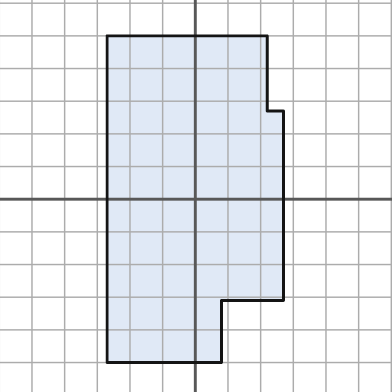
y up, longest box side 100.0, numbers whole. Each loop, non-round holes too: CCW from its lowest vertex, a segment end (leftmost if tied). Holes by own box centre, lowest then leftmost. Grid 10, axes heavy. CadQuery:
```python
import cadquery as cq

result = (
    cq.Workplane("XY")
    .moveTo(-27.0, -50.0)
    .lineTo(8.0, -50.0)
    .lineTo(8.0, -31.0)
    .lineTo(27.0, -31.0)
    .lineTo(27.0, 27.0)
    .lineTo(22.0, 27.0)
    .lineTo(22.0, 50.0)
    .lineTo(-27.0, 50.0)
    .close()
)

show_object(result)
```